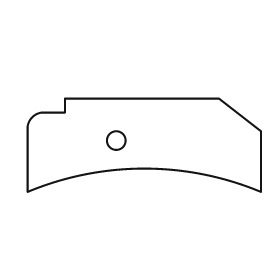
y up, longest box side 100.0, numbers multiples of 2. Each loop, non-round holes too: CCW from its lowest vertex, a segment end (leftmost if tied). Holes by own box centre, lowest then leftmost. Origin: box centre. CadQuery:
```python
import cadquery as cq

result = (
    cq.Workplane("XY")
    .moveTo(-50.0, -20.0)
    .threePointArc((0.0, -10.0), (50.0, -20.0))
    .lineTo(50.0, 6.0)
    .lineTo(32.0, 20.0)
    .lineTo(-34.0, 20.0)
    .lineTo(-34.0, 14.0)
    .lineTo(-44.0, 14.0)
    .threePointArc((-48.0, 12.0), (-50.0, 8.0))
    .close()
    .moveTo(-12.0, 2.0)
    .circle(4.0)
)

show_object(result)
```